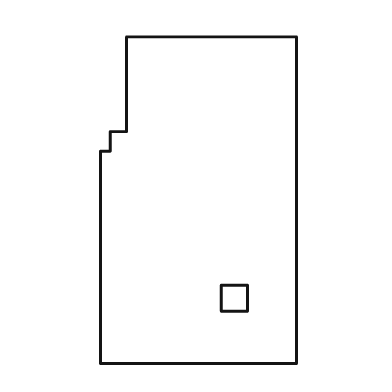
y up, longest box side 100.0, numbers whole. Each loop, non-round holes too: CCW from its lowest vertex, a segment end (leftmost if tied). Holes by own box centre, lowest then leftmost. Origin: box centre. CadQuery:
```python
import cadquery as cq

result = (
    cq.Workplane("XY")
    .moveTo(-30.0, -50.0)
    .lineTo(30.0, -50.0)
    .lineTo(30.0, 50.0)
    .lineTo(-22.0, 50.0)
    .lineTo(-22.0, 21.0)
    .lineTo(-27.0, 21.0)
    .lineTo(-27.0, 15.0)
    .lineTo(-30.0, 15.0)
    .close()
    .moveTo(7.0, -34.0)
    .lineTo(15.0, -34.0)
    .lineTo(15.0, -26.0)
    .lineTo(7.0, -26.0)
    .close()
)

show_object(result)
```